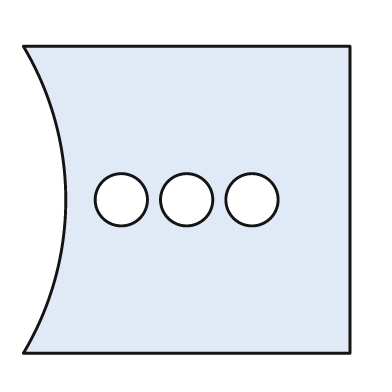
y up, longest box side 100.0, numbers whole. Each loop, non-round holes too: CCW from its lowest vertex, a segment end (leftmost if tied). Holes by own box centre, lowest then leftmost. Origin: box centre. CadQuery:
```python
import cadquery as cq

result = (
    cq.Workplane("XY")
    .moveTo(-50.0, -47.0)
    .lineTo(50.0, -47.0)
    .lineTo(50.0, 47.0)
    .lineTo(-50.0, 47.0)
    .threePointArc((-37.0, 0.0), (-50.0, -47.0))
    .close()
    .moveTo(-20.0, 0.0)
    .circle(8.0)
    .moveTo(0.0, 0.0)
    .circle(8.0)
    .moveTo(20.0, 0.0)
    .circle(8.0)
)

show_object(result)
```